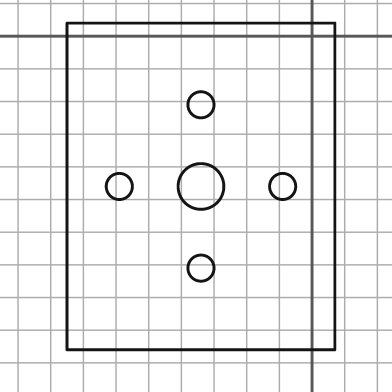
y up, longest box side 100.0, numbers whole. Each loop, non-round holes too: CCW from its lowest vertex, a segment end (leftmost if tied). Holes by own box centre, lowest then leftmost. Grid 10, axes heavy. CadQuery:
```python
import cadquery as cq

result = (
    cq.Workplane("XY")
    .moveTo(-75.0, -96.0)
    .lineTo(7.0, -96.0)
    .lineTo(7.0, 4.0)
    .lineTo(-75.0, 4.0)
    .close()
    .moveTo(-34.0, -71.0)
    .circle(4.0)
    .moveTo(-59.0, -46.0)
    .circle(4.0)
    .moveTo(-34.0, -46.0)
    .circle(7.0)
    .moveTo(-9.0, -46.0)
    .circle(4.0)
    .moveTo(-34.0, -21.0)
    .circle(4.0)
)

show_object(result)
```